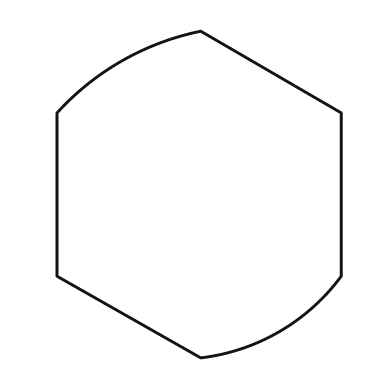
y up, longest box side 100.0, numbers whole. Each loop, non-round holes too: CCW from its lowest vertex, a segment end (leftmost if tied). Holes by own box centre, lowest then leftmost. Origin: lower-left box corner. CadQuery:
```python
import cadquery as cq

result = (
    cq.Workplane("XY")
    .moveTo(44.0, 0.0)
    .threePointArc((68.0, 8.0), (87.0, 25.0))
    .lineTo(87.0, 75.0)
    .lineTo(44.0, 100.0)
    .threePointArc((20.0, 91.0), (0.0, 75.0))
    .lineTo(0.0, 25.0)
    .close()
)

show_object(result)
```